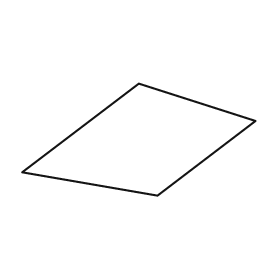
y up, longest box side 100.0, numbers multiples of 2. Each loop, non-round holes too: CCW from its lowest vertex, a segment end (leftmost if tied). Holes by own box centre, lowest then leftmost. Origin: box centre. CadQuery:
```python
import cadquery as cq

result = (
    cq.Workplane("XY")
    .moveTo(8.0, -24.0)
    .lineTo(50.0, 8.0)
    .lineTo(0.0, 24.0)
    .lineTo(-50.0, -14.0)
    .close()
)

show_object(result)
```